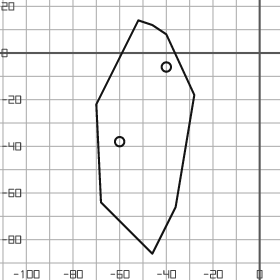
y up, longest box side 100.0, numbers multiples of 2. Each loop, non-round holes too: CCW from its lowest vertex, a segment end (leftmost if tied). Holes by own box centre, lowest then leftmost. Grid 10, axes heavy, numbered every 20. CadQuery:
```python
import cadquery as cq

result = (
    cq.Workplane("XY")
    .moveTo(-46.0, -86.0)
    .lineTo(-36.0, -66.0)
    .lineTo(-28.0, -18.0)
    .lineTo(-40.0, 8.0)
    .lineTo(-46.0, 12.0)
    .lineTo(-52.0, 14.0)
    .lineTo(-70.0, -22.0)
    .lineTo(-68.0, -64.0)
    .close()
    .moveTo(-60.0, -38.0)
    .circle(2.0)
    .moveTo(-40.0, -6.0)
    .circle(2.0)
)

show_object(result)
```